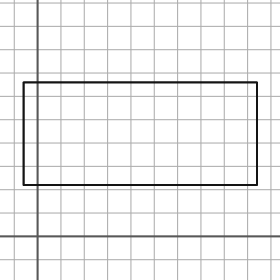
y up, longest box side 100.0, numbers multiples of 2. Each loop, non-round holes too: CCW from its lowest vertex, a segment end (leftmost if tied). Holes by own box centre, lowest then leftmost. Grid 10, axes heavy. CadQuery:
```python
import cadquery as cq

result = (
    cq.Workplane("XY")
    .moveTo(-6.0, 22.0)
    .lineTo(94.0, 22.0)
    .lineTo(94.0, 66.0)
    .lineTo(-6.0, 66.0)
    .close()
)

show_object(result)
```